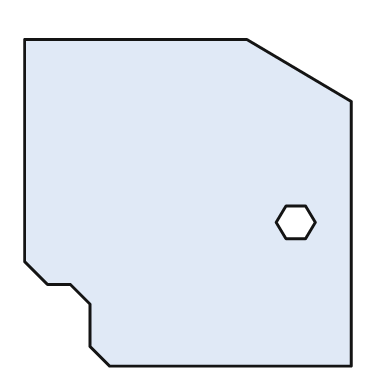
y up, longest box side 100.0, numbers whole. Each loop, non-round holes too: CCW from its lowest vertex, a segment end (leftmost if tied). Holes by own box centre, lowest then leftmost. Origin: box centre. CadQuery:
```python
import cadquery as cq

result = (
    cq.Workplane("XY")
    .moveTo(-24.0, -50.0)
    .lineTo(50.0, -50.0)
    .lineTo(50.0, 31.0)
    .lineTo(18.0, 50.0)
    .lineTo(-50.0, 50.0)
    .lineTo(-50.0, -18.0)
    .lineTo(-43.0, -25.0)
    .lineTo(-36.0, -25.0)
    .lineTo(-30.0, -31.0)
    .lineTo(-30.0, -44.0)
    .close()
    .moveTo(30.0, -11.0)
    .lineTo(36.0, -11.0)
    .lineTo(39.0, -6.0)
    .lineTo(36.0, -1.0)
    .lineTo(30.0, -1.0)
    .lineTo(27.0, -6.0)
    .close()
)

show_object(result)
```